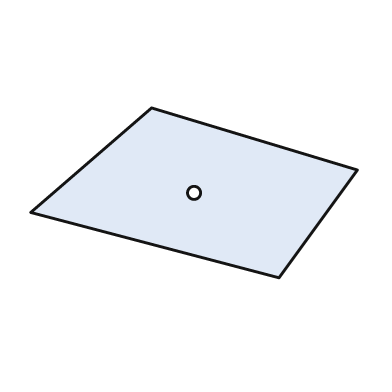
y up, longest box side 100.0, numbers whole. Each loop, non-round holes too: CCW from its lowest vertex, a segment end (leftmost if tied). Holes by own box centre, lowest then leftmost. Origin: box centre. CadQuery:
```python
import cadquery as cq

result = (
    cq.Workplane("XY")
    .moveTo(26.0, -26.0)
    .lineTo(50.0, 7.0)
    .lineTo(-13.0, 26.0)
    .lineTo(-50.0, -6.0)
    .close()
    .moveTo(0.0, 0.0)
    .circle(2.0)
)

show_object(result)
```